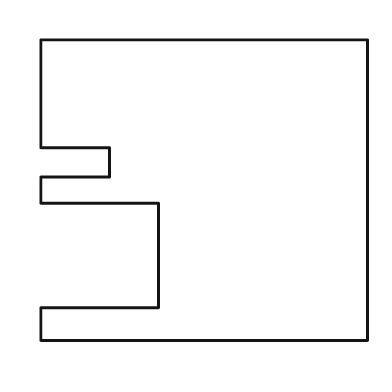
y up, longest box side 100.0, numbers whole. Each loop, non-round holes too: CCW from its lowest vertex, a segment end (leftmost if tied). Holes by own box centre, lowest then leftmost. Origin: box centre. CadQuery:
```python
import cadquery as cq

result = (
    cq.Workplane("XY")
    .moveTo(-50.0, -46.0)
    .lineTo(50.0, -46.0)
    .lineTo(50.0, 46.0)
    .lineTo(-50.0, 46.0)
    .lineTo(-50.0, 13.0)
    .lineTo(-29.0, 13.0)
    .lineTo(-29.0, 4.0)
    .lineTo(-50.0, 4.0)
    .lineTo(-50.0, -4.0)
    .lineTo(-14.0, -4.0)
    .lineTo(-14.0, -36.0)
    .lineTo(-50.0, -36.0)
    .close()
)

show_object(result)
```